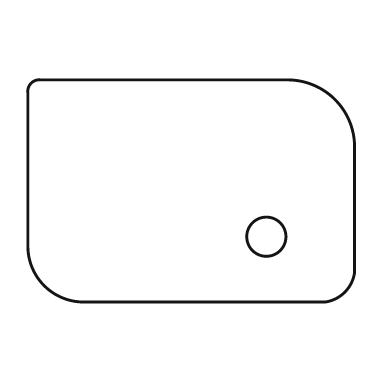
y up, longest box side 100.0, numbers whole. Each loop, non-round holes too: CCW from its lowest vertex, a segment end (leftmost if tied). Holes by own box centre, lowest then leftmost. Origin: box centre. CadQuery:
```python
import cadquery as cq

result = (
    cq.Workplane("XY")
    .moveTo(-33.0, -34.0)
    .lineTo(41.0, -34.0)
    .threePointArc((47.0, -31.0), (50.0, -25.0))
    .lineTo(50.0, 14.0)
    .threePointArc((44.0, 28.0), (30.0, 34.0))
    .lineTo(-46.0, 34.0)
    .threePointArc((-49.0, 33.0), (-50.0, 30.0))
    .lineTo(-50.0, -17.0)
    .threePointArc((-45.0, -29.0), (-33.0, -34.0))
    .close()
    .moveTo(23.0, -14.0)
    .circle(6.0)
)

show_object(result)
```